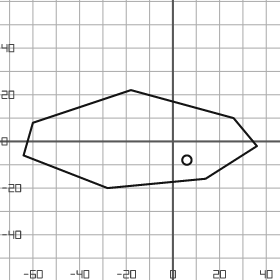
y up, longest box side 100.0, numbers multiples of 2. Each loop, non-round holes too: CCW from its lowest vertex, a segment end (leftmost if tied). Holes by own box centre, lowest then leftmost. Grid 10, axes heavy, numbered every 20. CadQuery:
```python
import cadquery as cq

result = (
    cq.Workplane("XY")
    .moveTo(-28.0, -20.0)
    .lineTo(14.0, -16.0)
    .lineTo(36.0, -2.0)
    .lineTo(26.0, 10.0)
    .lineTo(-18.0, 22.0)
    .lineTo(-60.0, 8.0)
    .lineTo(-64.0, -6.0)
    .close()
    .moveTo(6.0, -8.0)
    .circle(2.0)
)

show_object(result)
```